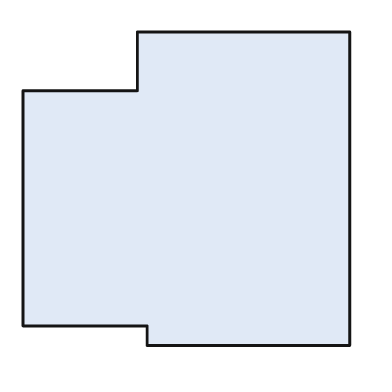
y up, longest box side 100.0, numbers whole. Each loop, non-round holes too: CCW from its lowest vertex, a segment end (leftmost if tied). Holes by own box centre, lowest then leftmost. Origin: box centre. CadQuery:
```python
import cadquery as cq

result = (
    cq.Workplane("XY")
    .moveTo(-12.0, -48.0)
    .lineTo(50.0, -48.0)
    .lineTo(50.0, 48.0)
    .lineTo(-15.0, 48.0)
    .lineTo(-15.0, 30.0)
    .lineTo(-50.0, 30.0)
    .lineTo(-50.0, -42.0)
    .lineTo(-12.0, -42.0)
    .close()
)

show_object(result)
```